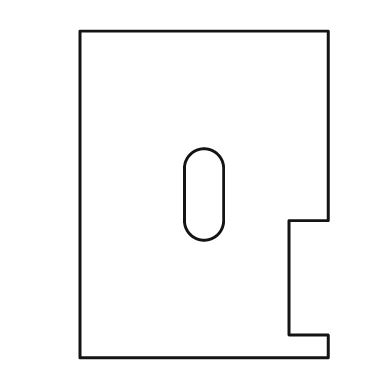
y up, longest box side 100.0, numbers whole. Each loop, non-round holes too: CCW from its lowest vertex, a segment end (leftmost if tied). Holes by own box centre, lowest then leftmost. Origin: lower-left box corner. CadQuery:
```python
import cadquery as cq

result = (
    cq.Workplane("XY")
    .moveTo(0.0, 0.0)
    .lineTo(76.0, 0.0)
    .lineTo(76.0, 7.0)
    .lineTo(64.0, 7.0)
    .lineTo(64.0, 42.0)
    .lineTo(76.0, 42.0)
    .lineTo(76.0, 100.0)
    .lineTo(0.0, 100.0)
    .close()
    .moveTo(32.0, 42.0)
    .threePointArc((38.0, 36.0), (44.0, 42.0))
    .lineTo(44.0, 58.0)
    .threePointArc((38.0, 64.0), (32.0, 58.0))
    .close()
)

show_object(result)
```